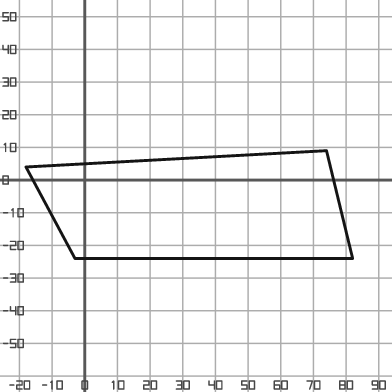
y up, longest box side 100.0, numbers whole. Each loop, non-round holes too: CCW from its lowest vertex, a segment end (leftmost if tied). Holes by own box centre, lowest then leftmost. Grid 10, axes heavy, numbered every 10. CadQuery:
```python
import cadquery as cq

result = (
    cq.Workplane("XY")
    .moveTo(-3.0, -24.0)
    .lineTo(82.0, -24.0)
    .lineTo(74.0, 9.0)
    .lineTo(-18.0, 4.0)
    .close()
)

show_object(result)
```